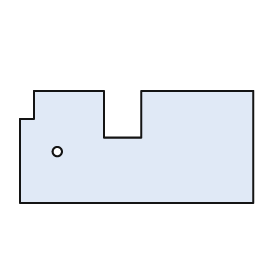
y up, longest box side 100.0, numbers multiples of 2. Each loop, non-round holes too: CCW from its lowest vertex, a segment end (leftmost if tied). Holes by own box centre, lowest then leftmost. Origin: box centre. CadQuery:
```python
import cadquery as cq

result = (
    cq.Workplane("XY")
    .moveTo(-50.0, -24.0)
    .lineTo(50.0, -24.0)
    .lineTo(50.0, 24.0)
    .lineTo(2.0, 24.0)
    .lineTo(2.0, 4.0)
    .lineTo(-14.0, 4.0)
    .lineTo(-14.0, 24.0)
    .lineTo(-44.0, 24.0)
    .lineTo(-44.0, 12.0)
    .lineTo(-50.0, 12.0)
    .close()
    .moveTo(-34.0, -2.0)
    .circle(2.0)
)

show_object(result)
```